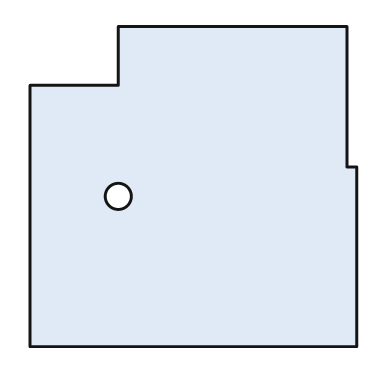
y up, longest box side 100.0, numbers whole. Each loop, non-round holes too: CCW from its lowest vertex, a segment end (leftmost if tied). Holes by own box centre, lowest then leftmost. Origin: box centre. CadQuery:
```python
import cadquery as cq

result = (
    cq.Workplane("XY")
    .moveTo(-50.0, -49.0)
    .lineTo(50.0, -49.0)
    .lineTo(50.0, 6.0)
    .lineTo(47.0, 6.0)
    .lineTo(47.0, 49.0)
    .lineTo(-23.0, 49.0)
    .lineTo(-23.0, 31.0)
    .lineTo(-50.0, 31.0)
    .close()
    .moveTo(-23.0, -3.0)
    .circle(4.0)
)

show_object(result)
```